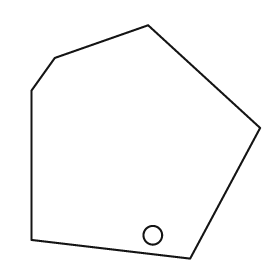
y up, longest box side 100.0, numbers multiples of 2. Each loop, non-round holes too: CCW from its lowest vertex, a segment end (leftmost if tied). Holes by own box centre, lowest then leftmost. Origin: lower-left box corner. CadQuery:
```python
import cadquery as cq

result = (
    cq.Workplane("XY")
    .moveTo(68.0, 0.0)
    .lineTo(98.0, 56.0)
    .lineTo(50.0, 100.0)
    .lineTo(10.0, 86.0)
    .lineTo(0.0, 72.0)
    .lineTo(0.0, 8.0)
    .close()
    .moveTo(52.0, 10.0)
    .circle(4.0)
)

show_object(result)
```